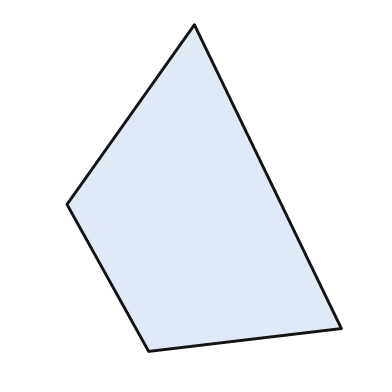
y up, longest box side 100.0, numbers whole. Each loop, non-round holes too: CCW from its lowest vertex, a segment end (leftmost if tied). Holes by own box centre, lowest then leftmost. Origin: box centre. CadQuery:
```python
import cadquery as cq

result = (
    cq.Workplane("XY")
    .moveTo(-17.0, -50.0)
    .lineTo(42.0, -43.0)
    .lineTo(-3.0, 50.0)
    .lineTo(-42.0, -5.0)
    .close()
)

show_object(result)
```